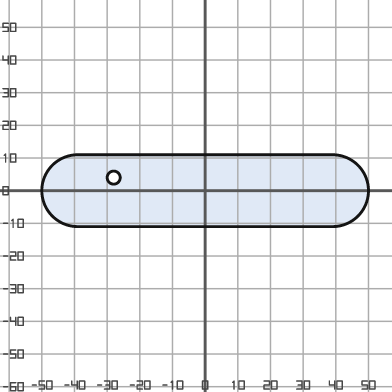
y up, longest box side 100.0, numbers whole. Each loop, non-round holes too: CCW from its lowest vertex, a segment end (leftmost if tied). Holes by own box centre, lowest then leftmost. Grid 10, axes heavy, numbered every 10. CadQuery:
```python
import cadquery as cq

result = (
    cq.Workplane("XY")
    .moveTo(-39.0, -11.0)
    .lineTo(39.0, -11.0)
    .threePointArc((50.0, 0.0), (39.0, 11.0))
    .lineTo(-39.0, 11.0)
    .threePointArc((-50.0, 0.0), (-39.0, -11.0))
    .close()
    .moveTo(-28.0, 4.0)
    .circle(2.0)
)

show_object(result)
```